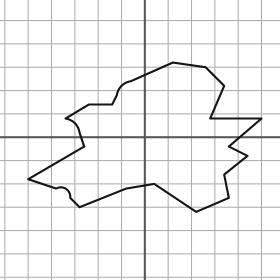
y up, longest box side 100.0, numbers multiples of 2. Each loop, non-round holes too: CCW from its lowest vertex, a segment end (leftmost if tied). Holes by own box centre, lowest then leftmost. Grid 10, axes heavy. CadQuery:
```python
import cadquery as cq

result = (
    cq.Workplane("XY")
    .moveTo(22.0, -32.0)
    .lineTo(36.0, -26.0)
    .lineTo(34.0, -16.0)
    .lineTo(44.0, -8.0)
    .lineTo(36.0, -4.0)
    .lineTo(50.0, 8.0)
    .lineTo(28.0, 8.0)
    .lineTo(34.0, 22.0)
    .lineTo(26.0, 30.0)
    .lineTo(12.0, 32.0)
    .lineTo(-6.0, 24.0)
    .threePointArc((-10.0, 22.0), (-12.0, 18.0))
    .lineTo(-14.0, 14.0)
    .lineTo(-24.0, 14.0)
    .lineTo(-34.0, 8.0)
    .threePointArc((-30.0, 6.0), (-28.0, 2.0))
    .lineTo(-26.0, -4.0)
    .lineTo(-50.0, -18.0)
    .lineTo(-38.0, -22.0)
    .threePointArc((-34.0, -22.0), (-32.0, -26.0))
    .lineTo(-28.0, -30.0)
    .lineTo(-8.0, -22.0)
    .lineTo(4.0, -20.0)
    .close()
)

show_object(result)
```